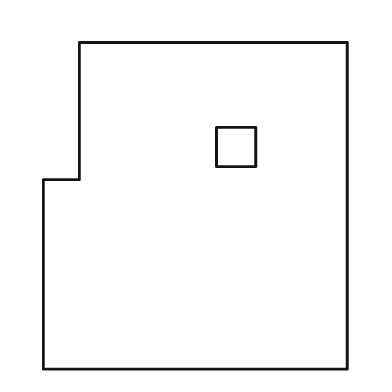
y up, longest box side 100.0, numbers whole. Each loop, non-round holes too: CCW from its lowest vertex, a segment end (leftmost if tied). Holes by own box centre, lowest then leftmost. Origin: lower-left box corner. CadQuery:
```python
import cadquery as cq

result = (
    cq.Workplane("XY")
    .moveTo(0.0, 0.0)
    .lineTo(93.0, 0.0)
    .lineTo(93.0, 100.0)
    .lineTo(11.0, 100.0)
    .lineTo(11.0, 58.0)
    .lineTo(0.0, 58.0)
    .close()
    .moveTo(53.0, 62.0)
    .lineTo(65.0, 62.0)
    .lineTo(65.0, 74.0)
    .lineTo(53.0, 74.0)
    .close()
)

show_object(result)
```